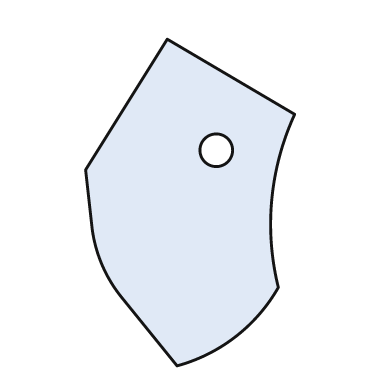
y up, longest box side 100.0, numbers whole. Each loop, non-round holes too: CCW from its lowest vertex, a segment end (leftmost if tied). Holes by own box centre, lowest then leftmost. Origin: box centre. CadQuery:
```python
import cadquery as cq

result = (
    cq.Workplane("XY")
    .moveTo(-4.0, -50.0)
    .threePointArc((14.0, -41.0), (27.0, -26.0))
    .threePointArc((25.0, 1.0), (32.0, 27.0))
    .lineTo(-7.0, 50.0)
    .lineTo(-32.0, 10.0)
    .lineTo(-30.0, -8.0)
    .threePointArc((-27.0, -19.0), (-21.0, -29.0))
    .close()
    .moveTo(8.0, 16.0)
    .circle(5.0)
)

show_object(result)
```